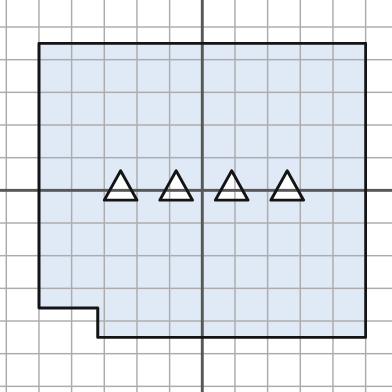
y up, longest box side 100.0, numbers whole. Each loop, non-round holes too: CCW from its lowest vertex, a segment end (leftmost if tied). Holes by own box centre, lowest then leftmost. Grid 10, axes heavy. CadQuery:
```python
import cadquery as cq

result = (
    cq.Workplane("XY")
    .moveTo(-32.0, -45.0)
    .lineTo(50.0, -45.0)
    .lineTo(50.0, 45.0)
    .lineTo(-50.0, 45.0)
    .lineTo(-50.0, -36.0)
    .lineTo(-32.0, -36.0)
    .close()
    .moveTo(-30.0, -3.0)
    .lineTo(-20.0, -3.0)
    .lineTo(-25.0, 6.0)
    .close()
    .moveTo(-13.0, -3.0)
    .lineTo(-3.0, -3.0)
    .lineTo(-8.0, 6.0)
    .close()
    .moveTo(4.0, -3.0)
    .lineTo(14.0, -3.0)
    .lineTo(9.0, 6.0)
    .close()
    .moveTo(21.0, -3.0)
    .lineTo(31.0, -3.0)
    .lineTo(26.0, 6.0)
    .close()
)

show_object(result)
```